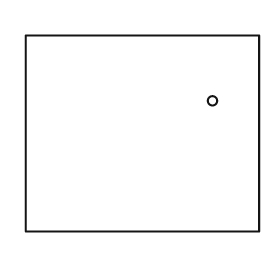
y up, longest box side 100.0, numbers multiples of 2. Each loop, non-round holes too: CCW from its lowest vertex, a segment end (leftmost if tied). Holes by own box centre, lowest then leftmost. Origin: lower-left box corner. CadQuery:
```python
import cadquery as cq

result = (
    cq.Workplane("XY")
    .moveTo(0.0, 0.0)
    .lineTo(100.0, 0.0)
    .lineTo(100.0, 84.0)
    .lineTo(0.0, 84.0)
    .close()
    .moveTo(80.0, 56.0)
    .circle(2.0)
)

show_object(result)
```